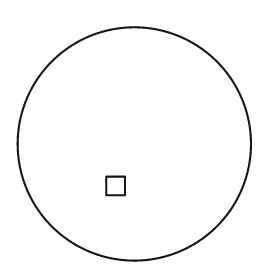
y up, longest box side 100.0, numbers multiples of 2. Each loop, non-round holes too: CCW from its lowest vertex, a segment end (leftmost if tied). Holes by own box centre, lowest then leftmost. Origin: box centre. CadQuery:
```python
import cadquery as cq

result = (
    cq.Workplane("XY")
    .moveTo(0.0, 0.0)
    .circle(50.0)
    .moveTo(-12.0, -22.0)
    .lineTo(-4.0, -22.0)
    .lineTo(-4.0, -14.0)
    .lineTo(-12.0, -14.0)
    .close()
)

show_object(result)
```